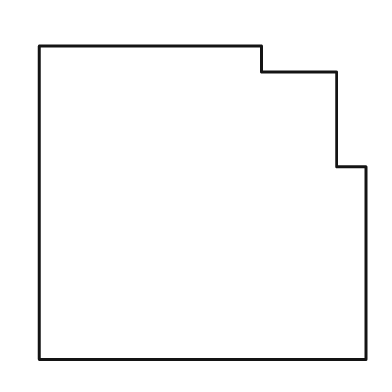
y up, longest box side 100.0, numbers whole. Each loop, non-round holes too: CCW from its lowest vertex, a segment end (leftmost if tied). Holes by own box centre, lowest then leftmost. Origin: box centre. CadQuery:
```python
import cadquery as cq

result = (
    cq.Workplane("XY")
    .moveTo(-50.0, -48.0)
    .lineTo(50.0, -48.0)
    .lineTo(50.0, 11.0)
    .lineTo(41.0, 11.0)
    .lineTo(41.0, 40.0)
    .lineTo(18.0, 40.0)
    .lineTo(18.0, 48.0)
    .lineTo(-50.0, 48.0)
    .close()
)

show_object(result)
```